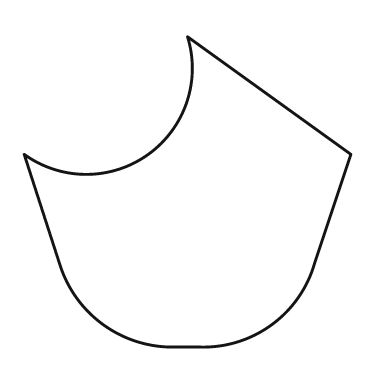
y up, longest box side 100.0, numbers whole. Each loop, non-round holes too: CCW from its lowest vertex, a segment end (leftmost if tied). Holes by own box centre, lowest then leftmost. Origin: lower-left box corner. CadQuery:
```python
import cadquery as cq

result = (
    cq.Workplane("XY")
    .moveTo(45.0, 0.0)
    .lineTo(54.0, 0.0)
    .threePointArc((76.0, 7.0), (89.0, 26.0))
    .lineTo(100.0, 59.0)
    .lineTo(50.0, 95.0)
    .threePointArc((38.0, 59.0), (0.0, 59.0))
    .lineTo(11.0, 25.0)
    .threePointArc((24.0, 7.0), (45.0, 0.0))
    .close()
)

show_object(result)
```